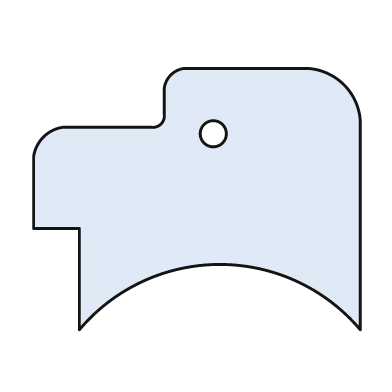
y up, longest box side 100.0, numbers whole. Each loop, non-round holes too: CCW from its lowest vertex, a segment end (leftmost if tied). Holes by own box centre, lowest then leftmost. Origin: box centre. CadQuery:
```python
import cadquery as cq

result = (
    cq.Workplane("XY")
    .moveTo(-36.0, -40.0)
    .threePointArc((7.0, -20.0), (50.0, -40.0))
    .lineTo(50.0, 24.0)
    .threePointArc((45.0, 35.0), (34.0, 40.0))
    .lineTo(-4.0, 40.0)
    .threePointArc((-8.0, 38.0), (-10.0, 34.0))
    .lineTo(-10.0, 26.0)
    .threePointArc((-11.0, 23.0), (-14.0, 22.0))
    .lineTo(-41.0, 22.0)
    .threePointArc((-47.0, 19.0), (-50.0, 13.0))
    .lineTo(-50.0, -9.0)
    .lineTo(-36.0, -9.0)
    .close()
    .moveTo(5.0, 20.0)
    .circle(4.0)
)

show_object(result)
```